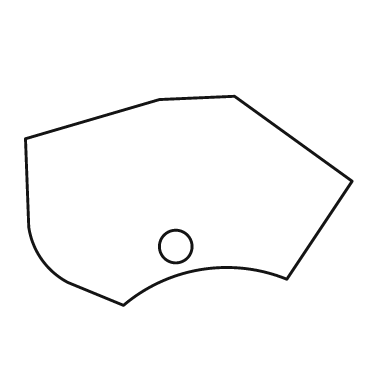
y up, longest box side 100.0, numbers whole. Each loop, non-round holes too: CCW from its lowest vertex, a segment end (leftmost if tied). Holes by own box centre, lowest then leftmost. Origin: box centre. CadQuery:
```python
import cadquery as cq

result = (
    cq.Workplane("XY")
    .moveTo(-20.0, -32.0)
    .threePointArc((4.0, -21.0), (30.0, -24.0))
    .lineTo(50.0, 6.0)
    .lineTo(14.0, 32.0)
    .lineTo(-9.0, 31.0)
    .lineTo(-50.0, 19.0)
    .lineTo(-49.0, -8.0)
    .threePointArc((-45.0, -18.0), (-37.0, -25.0))
    .close()
    .moveTo(-4.0, -14.0)
    .circle(5.0)
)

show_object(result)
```